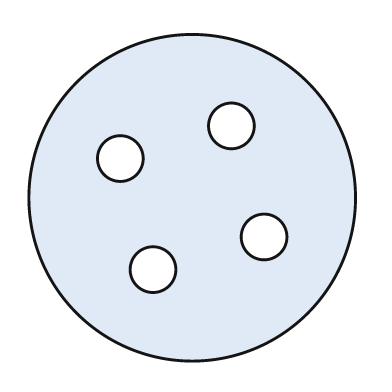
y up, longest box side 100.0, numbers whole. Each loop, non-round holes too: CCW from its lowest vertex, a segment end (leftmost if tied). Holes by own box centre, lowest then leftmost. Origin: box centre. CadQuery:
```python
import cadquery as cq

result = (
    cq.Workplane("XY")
    .moveTo(0.0, 0.0)
    .circle(50.0)
    .moveTo(-12.0, -22.0)
    .circle(7.0)
    .moveTo(22.0, -12.0)
    .circle(7.0)
    .moveTo(-22.0, 12.0)
    .circle(7.0)
    .moveTo(12.0, 22.0)
    .circle(7.0)
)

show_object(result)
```